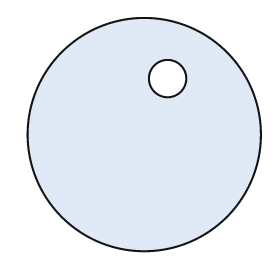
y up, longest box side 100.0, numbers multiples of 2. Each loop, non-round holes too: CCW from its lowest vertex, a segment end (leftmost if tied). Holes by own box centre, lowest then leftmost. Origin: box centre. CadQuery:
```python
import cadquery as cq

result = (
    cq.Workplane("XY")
    .moveTo(0.0, 0.0)
    .circle(50.0)
    .moveTo(10.0, 24.0)
    .circle(8.0)
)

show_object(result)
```